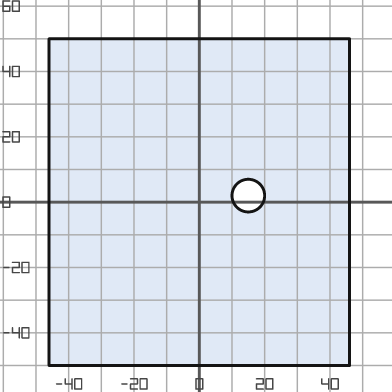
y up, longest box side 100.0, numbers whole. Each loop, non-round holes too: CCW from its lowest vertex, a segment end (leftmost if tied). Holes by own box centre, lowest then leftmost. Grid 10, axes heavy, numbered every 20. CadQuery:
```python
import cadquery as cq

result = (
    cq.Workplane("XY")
    .moveTo(-46.0, -50.0)
    .lineTo(46.0, -50.0)
    .lineTo(46.0, 50.0)
    .lineTo(-46.0, 50.0)
    .close()
    .moveTo(15.0, 2.0)
    .circle(5.0)
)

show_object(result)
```